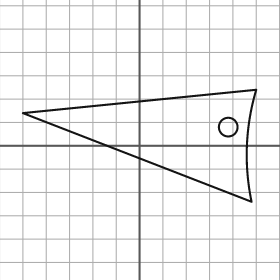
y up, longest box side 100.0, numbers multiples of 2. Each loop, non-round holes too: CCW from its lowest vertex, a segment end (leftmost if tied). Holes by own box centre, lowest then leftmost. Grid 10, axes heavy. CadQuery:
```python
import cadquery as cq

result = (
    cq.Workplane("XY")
    .moveTo(48.0, -24.0)
    .threePointArc((46.0, 0.0), (50.0, 24.0))
    .lineTo(-50.0, 14.0)
    .close()
    .moveTo(38.0, 8.0)
    .circle(4.0)
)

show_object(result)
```